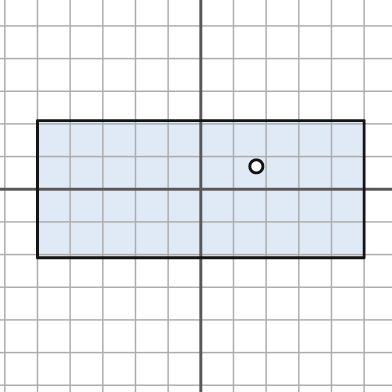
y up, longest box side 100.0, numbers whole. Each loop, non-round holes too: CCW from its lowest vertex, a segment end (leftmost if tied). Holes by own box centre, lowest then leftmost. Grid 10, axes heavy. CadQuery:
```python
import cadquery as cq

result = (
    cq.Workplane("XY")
    .moveTo(-50.0, -21.0)
    .lineTo(50.0, -21.0)
    .lineTo(50.0, 21.0)
    .lineTo(-50.0, 21.0)
    .close()
    .moveTo(17.0, 7.0)
    .circle(2.0)
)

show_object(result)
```